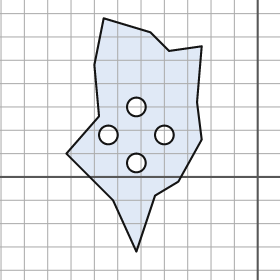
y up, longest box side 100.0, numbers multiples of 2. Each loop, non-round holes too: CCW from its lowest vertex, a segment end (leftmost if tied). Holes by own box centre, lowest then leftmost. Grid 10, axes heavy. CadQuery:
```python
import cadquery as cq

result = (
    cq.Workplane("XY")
    .moveTo(-52.0, -32.0)
    .lineTo(-44.0, -8.0)
    .lineTo(-34.0, -2.0)
    .lineTo(-24.0, 16.0)
    .lineTo(-26.0, 32.0)
    .lineTo(-24.0, 56.0)
    .lineTo(-38.0, 54.0)
    .lineTo(-46.0, 62.0)
    .lineTo(-66.0, 68.0)
    .lineTo(-70.0, 48.0)
    .lineTo(-68.0, 26.0)
    .lineTo(-82.0, 10.0)
    .lineTo(-62.0, -10.0)
    .close()
    .moveTo(-52.0, 6.0)
    .circle(4.0)
    .moveTo(-64.0, 18.0)
    .circle(4.0)
    .moveTo(-40.0, 18.0)
    .circle(4.0)
    .moveTo(-52.0, 30.0)
    .circle(4.0)
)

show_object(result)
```